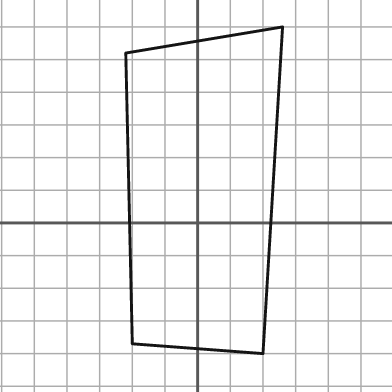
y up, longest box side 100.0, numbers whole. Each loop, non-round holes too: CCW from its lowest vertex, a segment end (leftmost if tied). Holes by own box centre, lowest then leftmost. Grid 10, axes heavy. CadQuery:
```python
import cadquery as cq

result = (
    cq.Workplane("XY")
    .moveTo(20.0, -40.0)
    .lineTo(26.0, 60.0)
    .lineTo(-22.0, 52.0)
    .lineTo(-20.0, -37.0)
    .close()
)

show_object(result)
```